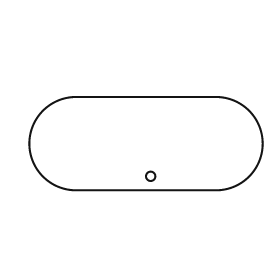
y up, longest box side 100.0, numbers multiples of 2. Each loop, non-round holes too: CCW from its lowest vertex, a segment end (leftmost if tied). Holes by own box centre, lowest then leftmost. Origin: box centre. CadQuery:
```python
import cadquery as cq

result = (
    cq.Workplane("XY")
    .moveTo(-30.0, -20.0)
    .lineTo(30.0, -20.0)
    .threePointArc((50.0, 0.0), (30.0, 20.0))
    .lineTo(-30.0, 20.0)
    .threePointArc((-50.0, 0.0), (-30.0, -20.0))
    .close()
    .moveTo(2.0, -14.0)
    .circle(2.0)
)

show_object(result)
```